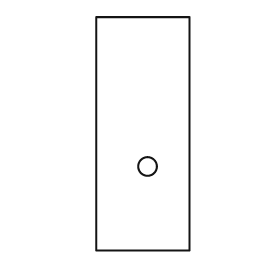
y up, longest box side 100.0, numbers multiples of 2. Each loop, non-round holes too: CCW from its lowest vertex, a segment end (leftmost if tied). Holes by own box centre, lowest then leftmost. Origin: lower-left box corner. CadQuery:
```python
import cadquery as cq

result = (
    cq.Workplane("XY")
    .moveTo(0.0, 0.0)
    .lineTo(40.0, 0.0)
    .lineTo(40.0, 100.0)
    .lineTo(0.0, 100.0)
    .close()
    .moveTo(22.0, 36.0)
    .circle(4.0)
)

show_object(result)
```